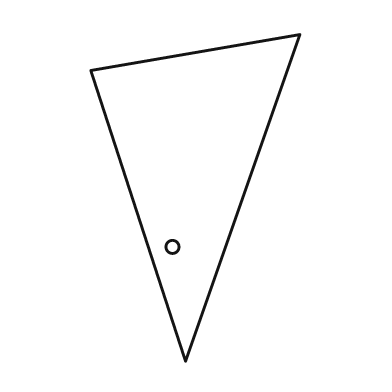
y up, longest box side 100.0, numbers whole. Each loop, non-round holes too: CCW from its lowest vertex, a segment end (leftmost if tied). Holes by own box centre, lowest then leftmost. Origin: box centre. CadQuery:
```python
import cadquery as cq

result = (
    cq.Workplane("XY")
    .moveTo(-3.0, -50.0)
    .lineTo(32.0, 50.0)
    .lineTo(-32.0, 39.0)
    .close()
    .moveTo(-7.0, -15.0)
    .circle(2.0)
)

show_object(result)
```